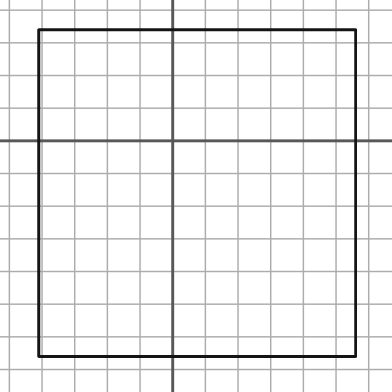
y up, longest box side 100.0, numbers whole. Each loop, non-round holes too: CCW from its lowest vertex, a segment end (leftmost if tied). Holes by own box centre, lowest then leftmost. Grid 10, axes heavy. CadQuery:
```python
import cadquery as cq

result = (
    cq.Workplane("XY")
    .moveTo(-41.0, -66.0)
    .lineTo(56.0, -66.0)
    .lineTo(56.0, 34.0)
    .lineTo(-41.0, 34.0)
    .close()
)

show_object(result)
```